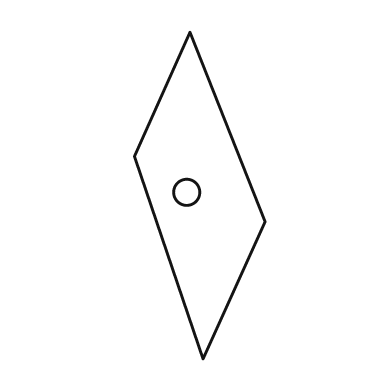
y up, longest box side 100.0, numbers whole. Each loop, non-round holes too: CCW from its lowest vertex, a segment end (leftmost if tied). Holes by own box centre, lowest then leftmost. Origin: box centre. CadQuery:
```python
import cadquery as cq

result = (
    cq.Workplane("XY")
    .moveTo(1.0, -50.0)
    .lineTo(20.0, -8.0)
    .lineTo(-3.0, 50.0)
    .lineTo(-20.0, 12.0)
    .close()
    .moveTo(-4.0, 1.0)
    .circle(4.0)
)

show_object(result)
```